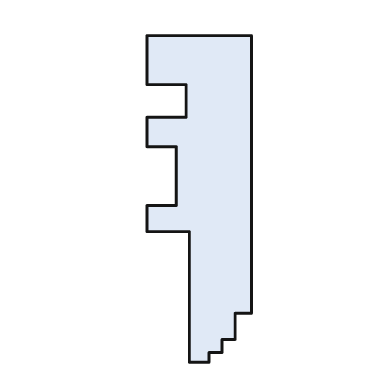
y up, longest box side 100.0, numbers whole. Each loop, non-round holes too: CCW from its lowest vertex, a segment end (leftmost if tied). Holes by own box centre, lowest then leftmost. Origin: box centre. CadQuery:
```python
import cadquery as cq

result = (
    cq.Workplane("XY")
    .moveTo(-3.0, -50.0)
    .lineTo(3.0, -50.0)
    .lineTo(3.0, -47.0)
    .lineTo(7.0, -47.0)
    .lineTo(7.0, -43.0)
    .lineTo(11.0, -43.0)
    .lineTo(11.0, -35.0)
    .lineTo(16.0, -35.0)
    .lineTo(16.0, 50.0)
    .lineTo(-16.0, 50.0)
    .lineTo(-16.0, 35.0)
    .lineTo(-4.0, 35.0)
    .lineTo(-4.0, 25.0)
    .lineTo(-16.0, 25.0)
    .lineTo(-16.0, 16.0)
    .lineTo(-7.0, 16.0)
    .lineTo(-7.0, -2.0)
    .lineTo(-16.0, -2.0)
    .lineTo(-16.0, -10.0)
    .lineTo(-3.0, -10.0)
    .close()
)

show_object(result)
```